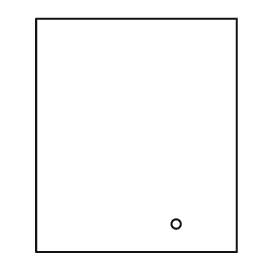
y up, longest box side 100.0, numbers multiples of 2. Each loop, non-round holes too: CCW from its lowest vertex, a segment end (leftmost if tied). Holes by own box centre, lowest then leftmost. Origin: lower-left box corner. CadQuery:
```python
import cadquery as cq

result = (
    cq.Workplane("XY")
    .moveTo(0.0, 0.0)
    .lineTo(86.0, 0.0)
    .lineTo(86.0, 100.0)
    .lineTo(0.0, 100.0)
    .close()
    .moveTo(60.0, 12.0)
    .circle(2.0)
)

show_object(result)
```